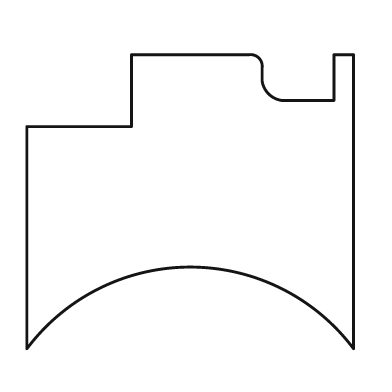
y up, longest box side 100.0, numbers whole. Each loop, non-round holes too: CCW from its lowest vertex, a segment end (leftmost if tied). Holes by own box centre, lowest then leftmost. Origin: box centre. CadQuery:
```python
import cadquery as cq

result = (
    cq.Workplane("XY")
    .moveTo(-50.0, -45.0)
    .threePointArc((0.0, -20.0), (50.0, -45.0))
    .lineTo(50.0, 45.0)
    .lineTo(44.0, 45.0)
    .lineTo(44.0, 31.0)
    .lineTo(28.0, 31.0)
    .threePointArc((24.0, 33.0), (22.0, 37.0))
    .lineTo(22.0, 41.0)
    .threePointArc((21.0, 44.0), (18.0, 45.0))
    .lineTo(-18.0, 45.0)
    .lineTo(-18.0, 23.0)
    .lineTo(-50.0, 23.0)
    .close()
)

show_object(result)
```